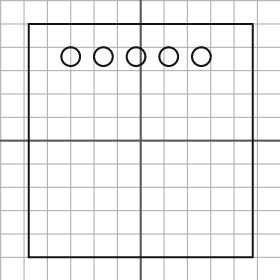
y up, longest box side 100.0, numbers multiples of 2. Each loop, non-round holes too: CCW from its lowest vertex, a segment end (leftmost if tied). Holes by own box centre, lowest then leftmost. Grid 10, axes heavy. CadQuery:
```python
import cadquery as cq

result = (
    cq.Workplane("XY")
    .moveTo(-48.0, -50.0)
    .lineTo(48.0, -50.0)
    .lineTo(48.0, 50.0)
    .lineTo(-48.0, 50.0)
    .close()
    .moveTo(-30.0, 36.0)
    .circle(4.0)
    .moveTo(-16.0, 36.0)
    .circle(4.0)
    .moveTo(-2.0, 36.0)
    .circle(4.0)
    .moveTo(12.0, 36.0)
    .circle(4.0)
    .moveTo(26.0, 36.0)
    .circle(4.0)
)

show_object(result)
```